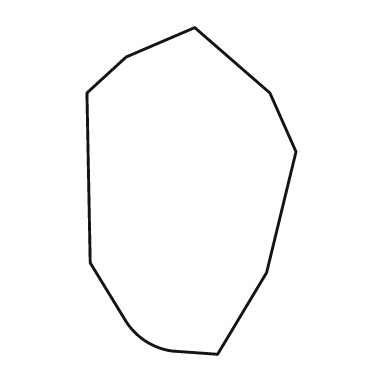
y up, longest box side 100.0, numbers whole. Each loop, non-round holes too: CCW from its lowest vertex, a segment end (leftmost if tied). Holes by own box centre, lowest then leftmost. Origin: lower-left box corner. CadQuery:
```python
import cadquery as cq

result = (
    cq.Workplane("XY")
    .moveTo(40.0, 0.0)
    .lineTo(55.0, 25.0)
    .lineTo(64.0, 62.0)
    .lineTo(56.0, 80.0)
    .lineTo(33.0, 100.0)
    .lineTo(12.0, 91.0)
    .lineTo(0.0, 80.0)
    .lineTo(1.0, 28.0)
    .lineTo(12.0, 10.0)
    .threePointArc((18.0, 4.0), (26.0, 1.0))
    .close()
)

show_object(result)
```